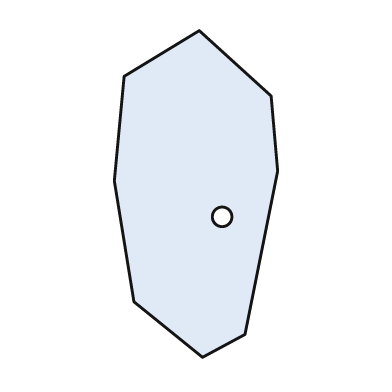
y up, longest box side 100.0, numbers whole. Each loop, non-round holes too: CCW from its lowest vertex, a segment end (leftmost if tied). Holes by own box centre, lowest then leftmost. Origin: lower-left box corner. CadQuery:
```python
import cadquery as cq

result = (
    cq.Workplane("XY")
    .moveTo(27.0, 0.0)
    .lineTo(40.0, 7.0)
    .lineTo(50.0, 57.0)
    .lineTo(48.0, 80.0)
    .lineTo(26.0, 100.0)
    .lineTo(3.0, 86.0)
    .lineTo(0.0, 54.0)
    .lineTo(6.0, 17.0)
    .close()
    .moveTo(33.0, 43.0)
    .circle(3.0)
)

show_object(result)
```